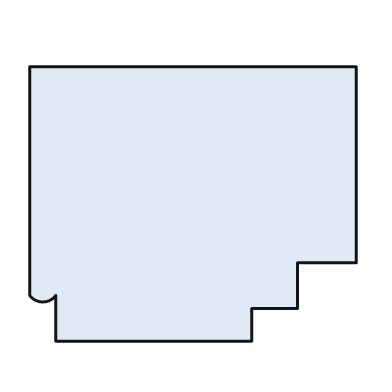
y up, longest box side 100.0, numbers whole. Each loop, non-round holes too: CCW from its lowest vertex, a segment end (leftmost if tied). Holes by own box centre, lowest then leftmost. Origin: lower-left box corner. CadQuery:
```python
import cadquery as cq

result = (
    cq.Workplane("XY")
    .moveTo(8.0, 0.0)
    .lineTo(68.0, 0.0)
    .lineTo(68.0, 10.0)
    .lineTo(82.0, 10.0)
    .lineTo(82.0, 24.0)
    .lineTo(100.0, 24.0)
    .lineTo(100.0, 84.0)
    .lineTo(0.0, 84.0)
    .lineTo(0.0, 14.0)
    .threePointArc((4.0, 12.0), (8.0, 14.0))
    .close()
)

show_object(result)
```